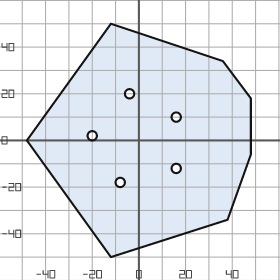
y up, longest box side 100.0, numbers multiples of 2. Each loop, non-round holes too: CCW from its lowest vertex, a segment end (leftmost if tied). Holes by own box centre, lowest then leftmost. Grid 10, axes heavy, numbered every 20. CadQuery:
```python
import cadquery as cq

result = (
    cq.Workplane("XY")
    .moveTo(-12.0, -50.0)
    .lineTo(38.0, -34.0)
    .lineTo(48.0, -6.0)
    .lineTo(48.0, 18.0)
    .lineTo(36.0, 34.0)
    .lineTo(-12.0, 50.0)
    .lineTo(-48.0, 0.0)
    .close()
    .moveTo(-8.0, -18.0)
    .circle(2.0)
    .moveTo(16.0, -12.0)
    .circle(2.0)
    .moveTo(-20.0, 2.0)
    .circle(2.0)
    .moveTo(16.0, 10.0)
    .circle(2.0)
    .moveTo(-4.0, 20.0)
    .circle(2.0)
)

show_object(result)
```